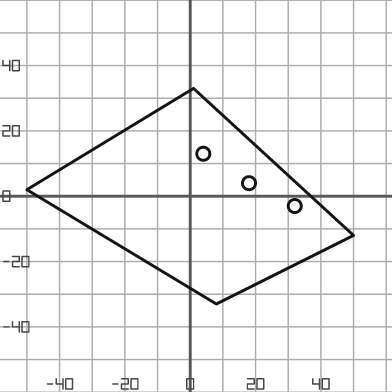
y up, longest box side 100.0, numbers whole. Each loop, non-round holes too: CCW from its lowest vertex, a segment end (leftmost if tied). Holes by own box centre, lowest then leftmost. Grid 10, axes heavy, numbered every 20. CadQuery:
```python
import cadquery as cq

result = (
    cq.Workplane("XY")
    .moveTo(8.0, -33.0)
    .lineTo(50.0, -12.0)
    .lineTo(1.0, 33.0)
    .lineTo(-50.0, 2.0)
    .close()
    .moveTo(32.0, -3.0)
    .circle(2.0)
    .moveTo(18.0, 4.0)
    .circle(2.0)
    .moveTo(4.0, 13.0)
    .circle(2.0)
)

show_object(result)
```